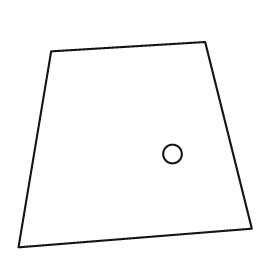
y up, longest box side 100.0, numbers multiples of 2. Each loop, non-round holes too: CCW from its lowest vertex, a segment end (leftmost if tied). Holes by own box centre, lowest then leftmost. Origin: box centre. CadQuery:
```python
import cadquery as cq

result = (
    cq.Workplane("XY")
    .moveTo(-50.0, -44.0)
    .lineTo(50.0, -36.0)
    .lineTo(30.0, 44.0)
    .lineTo(-36.0, 40.0)
    .close()
    .moveTo(16.0, -4.0)
    .circle(4.0)
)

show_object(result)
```